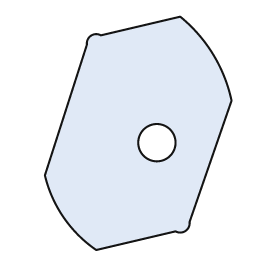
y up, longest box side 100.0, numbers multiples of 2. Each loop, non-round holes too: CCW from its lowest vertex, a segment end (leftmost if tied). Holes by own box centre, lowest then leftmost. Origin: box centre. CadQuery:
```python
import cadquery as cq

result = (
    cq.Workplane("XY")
    .moveTo(-18.0, -50.0)
    .lineTo(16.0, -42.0)
    .threePointArc((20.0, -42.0), (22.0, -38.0))
    .lineTo(40.0, 14.0)
    .threePointArc((32.0, 34.0), (18.0, 50.0))
    .lineTo(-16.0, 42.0)
    .threePointArc((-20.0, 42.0), (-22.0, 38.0))
    .lineTo(-40.0, -18.0)
    .threePointArc((-32.0, -36.0), (-18.0, -50.0))
    .close()
    .moveTo(8.0, -4.0)
    .circle(8.0)
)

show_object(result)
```